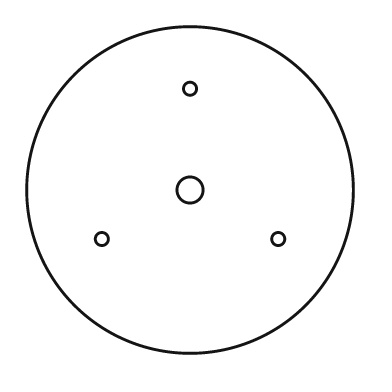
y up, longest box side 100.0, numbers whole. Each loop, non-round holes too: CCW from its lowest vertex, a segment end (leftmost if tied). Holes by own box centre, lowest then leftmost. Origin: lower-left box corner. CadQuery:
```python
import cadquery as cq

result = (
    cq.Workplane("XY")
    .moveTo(50.0, 50.0)
    .circle(50.0)
    .moveTo(23.0, 35.0)
    .circle(2.0)
    .moveTo(77.0, 35.0)
    .circle(2.0)
    .moveTo(50.0, 50.0)
    .circle(4.0)
    .moveTo(50.0, 81.0)
    .circle(2.0)
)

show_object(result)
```